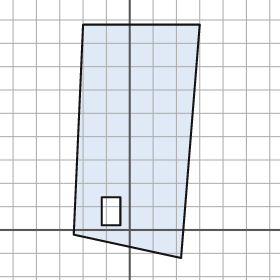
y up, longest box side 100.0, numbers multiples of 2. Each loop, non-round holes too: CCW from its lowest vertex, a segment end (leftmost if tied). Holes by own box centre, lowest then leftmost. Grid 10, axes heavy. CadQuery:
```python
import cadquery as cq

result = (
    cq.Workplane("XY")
    .moveTo(22.0, -12.0)
    .lineTo(30.0, 88.0)
    .lineTo(-20.0, 88.0)
    .lineTo(-24.0, -2.0)
    .close()
    .moveTo(-12.0, 2.0)
    .lineTo(-4.0, 2.0)
    .lineTo(-4.0, 14.0)
    .lineTo(-12.0, 14.0)
    .close()
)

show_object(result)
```